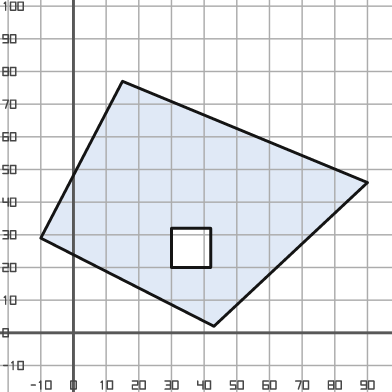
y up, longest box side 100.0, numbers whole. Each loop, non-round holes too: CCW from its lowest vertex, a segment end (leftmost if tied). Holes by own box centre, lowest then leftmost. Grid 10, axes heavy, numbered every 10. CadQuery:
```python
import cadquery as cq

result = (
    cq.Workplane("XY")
    .moveTo(43.0, 2.0)
    .lineTo(90.0, 46.0)
    .lineTo(15.0, 77.0)
    .lineTo(-10.0, 29.0)
    .close()
    .moveTo(30.0, 20.0)
    .lineTo(42.0, 20.0)
    .lineTo(42.0, 32.0)
    .lineTo(30.0, 32.0)
    .close()
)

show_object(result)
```